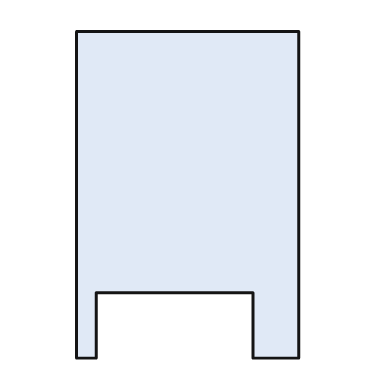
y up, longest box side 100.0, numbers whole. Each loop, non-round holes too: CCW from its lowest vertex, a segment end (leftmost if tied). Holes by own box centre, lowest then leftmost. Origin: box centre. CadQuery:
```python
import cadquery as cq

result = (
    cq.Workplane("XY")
    .moveTo(-34.0, -50.0)
    .lineTo(-28.0, -50.0)
    .lineTo(-28.0, -30.0)
    .lineTo(20.0, -30.0)
    .lineTo(20.0, -50.0)
    .lineTo(34.0, -50.0)
    .lineTo(34.0, 50.0)
    .lineTo(-34.0, 50.0)
    .close()
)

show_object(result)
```